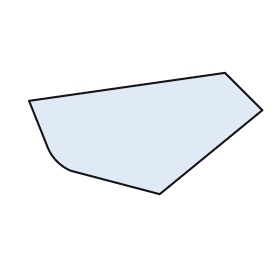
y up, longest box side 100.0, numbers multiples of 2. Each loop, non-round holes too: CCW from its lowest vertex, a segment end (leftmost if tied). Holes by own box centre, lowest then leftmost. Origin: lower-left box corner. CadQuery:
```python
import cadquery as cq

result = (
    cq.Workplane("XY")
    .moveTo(56.0, 0.0)
    .lineTo(100.0, 36.0)
    .lineTo(84.0, 52.0)
    .lineTo(0.0, 40.0)
    .lineTo(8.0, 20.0)
    .threePointArc((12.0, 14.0), (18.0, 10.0))
    .close()
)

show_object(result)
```